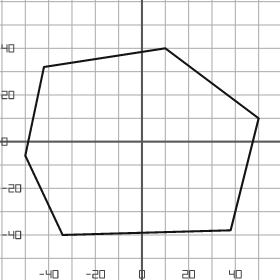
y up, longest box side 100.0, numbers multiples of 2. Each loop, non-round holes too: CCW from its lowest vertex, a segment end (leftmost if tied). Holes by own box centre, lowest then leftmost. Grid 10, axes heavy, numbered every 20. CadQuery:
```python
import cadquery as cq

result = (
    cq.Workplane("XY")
    .moveTo(-34.0, -40.0)
    .lineTo(38.0, -38.0)
    .lineTo(50.0, 10.0)
    .lineTo(10.0, 40.0)
    .lineTo(-42.0, 32.0)
    .lineTo(-50.0, -6.0)
    .close()
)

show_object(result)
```